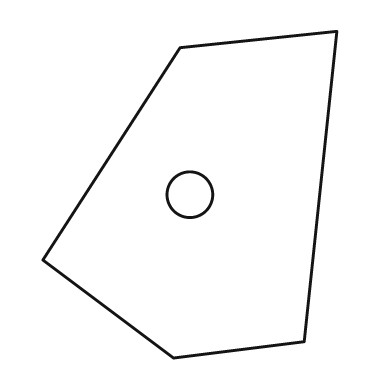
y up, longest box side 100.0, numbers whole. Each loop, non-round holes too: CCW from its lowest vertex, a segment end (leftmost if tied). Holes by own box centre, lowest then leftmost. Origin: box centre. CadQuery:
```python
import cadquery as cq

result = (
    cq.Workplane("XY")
    .moveTo(-5.0, -50.0)
    .lineTo(35.0, -45.0)
    .lineTo(45.0, 50.0)
    .lineTo(-3.0, 45.0)
    .lineTo(-45.0, -20.0)
    .close()
    .moveTo(0.0, 0.0)
    .circle(7.0)
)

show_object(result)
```